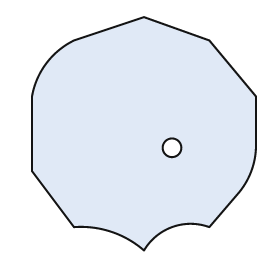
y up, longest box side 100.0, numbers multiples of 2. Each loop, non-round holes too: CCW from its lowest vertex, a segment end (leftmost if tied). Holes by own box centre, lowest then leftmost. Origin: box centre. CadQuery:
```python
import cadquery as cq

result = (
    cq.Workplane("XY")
    .moveTo(0.0, -50.0)
    .threePointArc((12.0, -40.0), (28.0, -40.0))
    .lineTo(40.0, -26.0)
    .threePointArc((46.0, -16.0), (48.0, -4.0))
    .lineTo(48.0, 16.0)
    .lineTo(28.0, 40.0)
    .lineTo(0.0, 50.0)
    .lineTo(-30.0, 40.0)
    .threePointArc((-42.0, 30.0), (-48.0, 16.0))
    .lineTo(-48.0, -16.0)
    .lineTo(-30.0, -40.0)
    .threePointArc((-14.0, -42.0), (0.0, -50.0))
    .close()
    .moveTo(12.0, -6.0)
    .circle(4.0)
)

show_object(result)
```